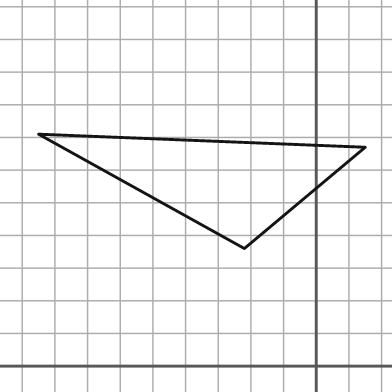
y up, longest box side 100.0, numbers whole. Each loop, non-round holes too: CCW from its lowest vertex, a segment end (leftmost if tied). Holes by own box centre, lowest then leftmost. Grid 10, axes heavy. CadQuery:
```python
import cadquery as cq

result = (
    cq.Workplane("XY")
    .moveTo(-22.0, 36.0)
    .lineTo(15.0, 67.0)
    .lineTo(-85.0, 71.0)
    .close()
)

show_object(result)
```